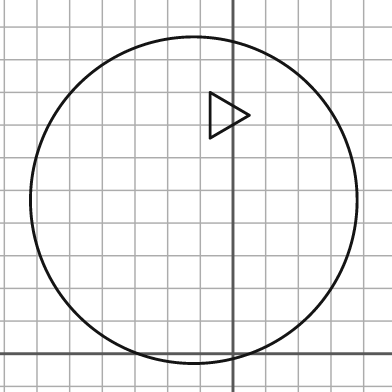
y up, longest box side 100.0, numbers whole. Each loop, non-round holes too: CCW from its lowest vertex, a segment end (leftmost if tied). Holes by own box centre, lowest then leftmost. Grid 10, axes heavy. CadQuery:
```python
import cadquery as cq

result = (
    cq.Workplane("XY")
    .moveTo(-12.0, 47.0)
    .circle(50.0)
    .moveTo(-7.0, 66.0)
    .lineTo(5.0, 73.0)
    .lineTo(-7.0, 80.0)
    .close()
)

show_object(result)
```